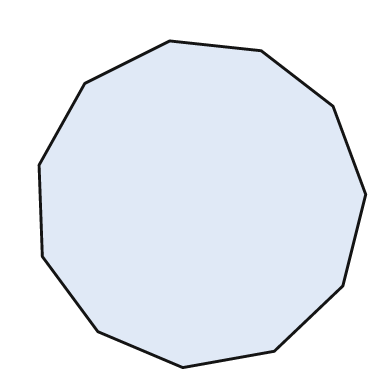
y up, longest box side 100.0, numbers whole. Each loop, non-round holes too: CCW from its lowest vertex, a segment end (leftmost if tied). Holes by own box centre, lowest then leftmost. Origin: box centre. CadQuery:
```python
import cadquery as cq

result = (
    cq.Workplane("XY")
    .moveTo(-6.0, -50.0)
    .lineTo(22.0, -45.0)
    .lineTo(43.0, -25.0)
    .lineTo(50.0, 3.0)
    .lineTo(40.0, 30.0)
    .lineTo(18.0, 47.0)
    .lineTo(-10.0, 50.0)
    .lineTo(-36.0, 37.0)
    .lineTo(-50.0, 12.0)
    .lineTo(-49.0, -16.0)
    .lineTo(-32.0, -39.0)
    .close()
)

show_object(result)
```